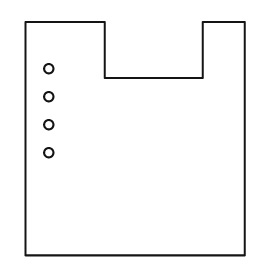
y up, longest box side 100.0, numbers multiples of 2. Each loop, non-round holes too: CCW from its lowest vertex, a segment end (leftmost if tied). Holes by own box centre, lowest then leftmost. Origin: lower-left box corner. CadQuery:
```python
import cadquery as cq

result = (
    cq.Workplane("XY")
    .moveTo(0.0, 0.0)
    .lineTo(94.0, 0.0)
    .lineTo(94.0, 100.0)
    .lineTo(76.0, 100.0)
    .lineTo(76.0, 76.0)
    .lineTo(34.0, 76.0)
    .lineTo(34.0, 100.0)
    .lineTo(0.0, 100.0)
    .close()
    .moveTo(10.0, 44.0)
    .circle(2.0)
    .moveTo(10.0, 56.0)
    .circle(2.0)
    .moveTo(10.0, 68.0)
    .circle(2.0)
    .moveTo(10.0, 80.0)
    .circle(2.0)
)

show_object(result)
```